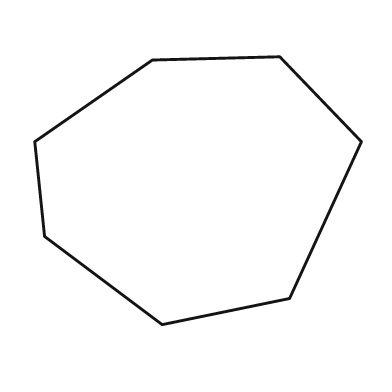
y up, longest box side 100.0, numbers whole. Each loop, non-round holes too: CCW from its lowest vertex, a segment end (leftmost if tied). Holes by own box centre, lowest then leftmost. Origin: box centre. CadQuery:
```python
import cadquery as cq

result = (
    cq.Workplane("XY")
    .moveTo(-11.0, -41.0)
    .lineTo(28.0, -33.0)
    .lineTo(50.0, 15.0)
    .lineTo(25.0, 41.0)
    .lineTo(-14.0, 40.0)
    .lineTo(-50.0, 15.0)
    .lineTo(-47.0, -14.0)
    .close()
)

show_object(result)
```